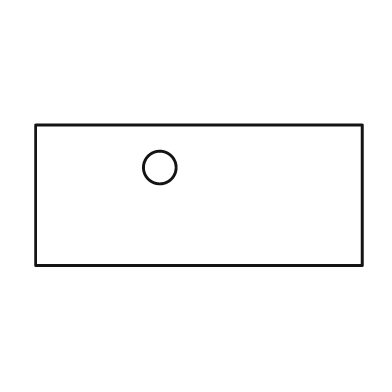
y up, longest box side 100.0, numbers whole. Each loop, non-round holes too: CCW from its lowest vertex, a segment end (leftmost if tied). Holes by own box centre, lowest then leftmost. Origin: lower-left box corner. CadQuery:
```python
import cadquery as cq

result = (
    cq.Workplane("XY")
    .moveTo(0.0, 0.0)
    .lineTo(100.0, 0.0)
    .lineTo(100.0, 43.0)
    .lineTo(0.0, 43.0)
    .close()
    .moveTo(38.0, 30.0)
    .circle(5.0)
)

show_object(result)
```